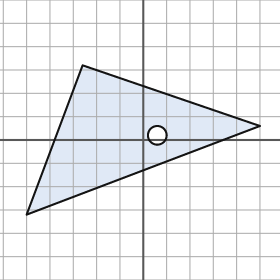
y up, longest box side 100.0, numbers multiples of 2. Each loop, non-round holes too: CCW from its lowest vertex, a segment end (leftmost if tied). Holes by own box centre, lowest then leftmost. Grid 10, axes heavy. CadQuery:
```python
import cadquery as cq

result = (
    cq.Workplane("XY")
    .moveTo(-50.0, -32.0)
    .lineTo(50.0, 6.0)
    .lineTo(-26.0, 32.0)
    .close()
    .moveTo(6.0, 2.0)
    .circle(4.0)
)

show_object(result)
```